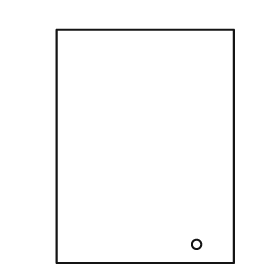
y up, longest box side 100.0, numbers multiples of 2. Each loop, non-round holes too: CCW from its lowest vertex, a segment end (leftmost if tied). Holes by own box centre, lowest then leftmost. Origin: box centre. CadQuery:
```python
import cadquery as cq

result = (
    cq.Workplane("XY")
    .moveTo(-38.0, -50.0)
    .lineTo(38.0, -50.0)
    .lineTo(38.0, 50.0)
    .lineTo(-38.0, 50.0)
    .close()
    .moveTo(22.0, -42.0)
    .circle(2.0)
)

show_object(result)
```